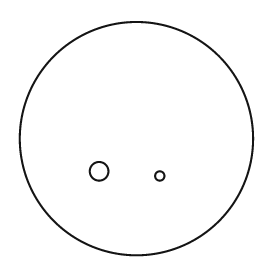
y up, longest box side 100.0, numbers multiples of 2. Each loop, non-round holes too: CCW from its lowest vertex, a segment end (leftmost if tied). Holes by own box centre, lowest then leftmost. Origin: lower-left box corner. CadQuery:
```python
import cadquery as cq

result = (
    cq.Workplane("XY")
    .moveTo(50.0, 50.0)
    .circle(50.0)
    .moveTo(60.0, 34.0)
    .circle(2.0)
    .moveTo(34.0, 36.0)
    .circle(4.0)
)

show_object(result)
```